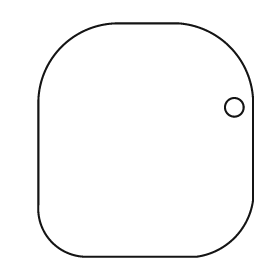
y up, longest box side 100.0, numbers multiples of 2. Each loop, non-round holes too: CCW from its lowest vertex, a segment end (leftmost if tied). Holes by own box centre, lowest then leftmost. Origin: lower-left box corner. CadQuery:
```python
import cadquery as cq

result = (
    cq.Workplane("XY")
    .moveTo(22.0, 0.0)
    .lineTo(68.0, 0.0)
    .threePointArc((84.0, 8.0), (92.0, 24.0))
    .lineTo(92.0, 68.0)
    .threePointArc((82.0, 90.0), (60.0, 100.0))
    .lineTo(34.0, 100.0)
    .threePointArc((10.0, 90.0), (0.0, 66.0))
    .lineTo(0.0, 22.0)
    .threePointArc((6.0, 6.0), (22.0, 0.0))
    .close()
    .moveTo(84.0, 64.0)
    .circle(4.0)
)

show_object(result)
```